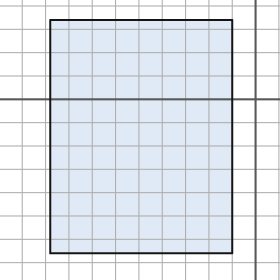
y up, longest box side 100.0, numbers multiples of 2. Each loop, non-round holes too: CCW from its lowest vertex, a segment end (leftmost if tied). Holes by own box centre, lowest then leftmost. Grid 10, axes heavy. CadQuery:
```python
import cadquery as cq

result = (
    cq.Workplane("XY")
    .moveTo(-88.0, -66.0)
    .lineTo(-10.0, -66.0)
    .lineTo(-10.0, 34.0)
    .lineTo(-88.0, 34.0)
    .close()
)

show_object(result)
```